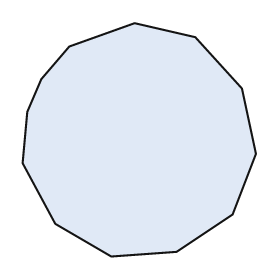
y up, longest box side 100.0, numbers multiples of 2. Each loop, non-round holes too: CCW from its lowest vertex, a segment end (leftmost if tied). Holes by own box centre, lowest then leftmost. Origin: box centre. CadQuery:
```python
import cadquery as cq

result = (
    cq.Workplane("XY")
    .moveTo(-12.0, -50.0)
    .lineTo(16.0, -48.0)
    .lineTo(40.0, -32.0)
    .lineTo(50.0, -6.0)
    .lineTo(44.0, 22.0)
    .lineTo(24.0, 44.0)
    .lineTo(-2.0, 50.0)
    .lineTo(-30.0, 40.0)
    .lineTo(-42.0, 26.0)
    .lineTo(-48.0, 12.0)
    .lineTo(-50.0, -10.0)
    .lineTo(-36.0, -36.0)
    .close()
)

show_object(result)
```